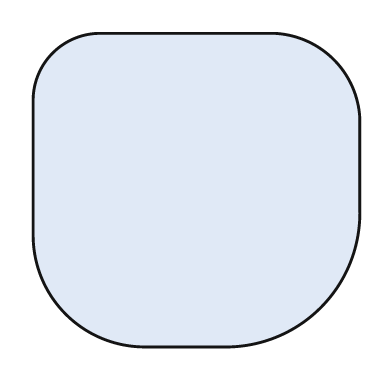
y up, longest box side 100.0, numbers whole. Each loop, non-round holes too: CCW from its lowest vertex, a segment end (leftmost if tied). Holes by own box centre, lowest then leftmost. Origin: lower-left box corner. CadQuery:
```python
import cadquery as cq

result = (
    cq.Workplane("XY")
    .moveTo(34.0, 0.0)
    .lineTo(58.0, 0.0)
    .threePointArc((88.0, 12.0), (100.0, 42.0))
    .lineTo(100.0, 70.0)
    .threePointArc((92.0, 88.0), (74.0, 96.0))
    .lineTo(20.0, 96.0)
    .threePointArc((6.0, 90.0), (0.0, 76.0))
    .lineTo(0.0, 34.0)
    .threePointArc((10.0, 10.0), (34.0, 0.0))
    .close()
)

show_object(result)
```